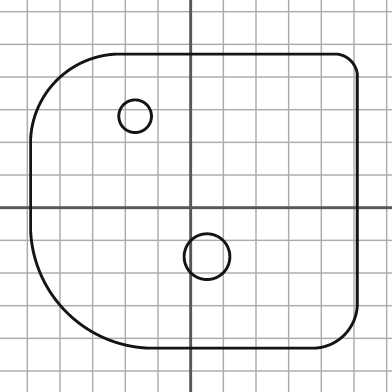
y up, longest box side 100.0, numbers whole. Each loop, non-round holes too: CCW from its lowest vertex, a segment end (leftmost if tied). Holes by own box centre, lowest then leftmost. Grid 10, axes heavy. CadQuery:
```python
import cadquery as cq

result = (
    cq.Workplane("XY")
    .moveTo(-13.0, -43.0)
    .lineTo(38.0, -43.0)
    .threePointArc((47.0, -39.0), (51.0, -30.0))
    .lineTo(51.0, 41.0)
    .threePointArc((49.0, 45.0), (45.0, 47.0))
    .lineTo(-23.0, 47.0)
    .threePointArc((-41.0, 39.0), (-49.0, 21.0))
    .lineTo(-49.0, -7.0)
    .threePointArc((-38.0, -32.0), (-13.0, -43.0))
    .close()
    .moveTo(5.0, -15.0)
    .circle(7.0)
    .moveTo(-17.0, 28.0)
    .circle(5.0)
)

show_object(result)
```